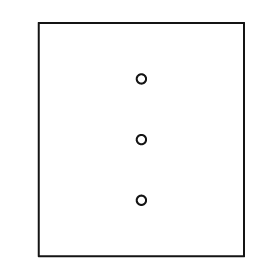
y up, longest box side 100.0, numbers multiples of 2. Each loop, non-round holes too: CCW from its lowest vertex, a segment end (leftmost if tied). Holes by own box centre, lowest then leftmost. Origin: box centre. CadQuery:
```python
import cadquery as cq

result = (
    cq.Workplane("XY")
    .moveTo(-44.0, -50.0)
    .lineTo(44.0, -50.0)
    .lineTo(44.0, 50.0)
    .lineTo(-44.0, 50.0)
    .close()
    .moveTo(0.0, -26.0)
    .circle(2.0)
    .moveTo(0.0, 0.0)
    .circle(2.0)
    .moveTo(0.0, 26.0)
    .circle(2.0)
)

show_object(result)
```